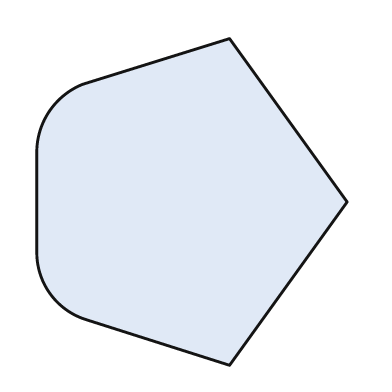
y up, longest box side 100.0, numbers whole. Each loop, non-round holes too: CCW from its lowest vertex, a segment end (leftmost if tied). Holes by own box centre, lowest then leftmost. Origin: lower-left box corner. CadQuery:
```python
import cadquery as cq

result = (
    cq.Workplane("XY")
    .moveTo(59.0, 0.0)
    .lineTo(95.0, 50.0)
    .lineTo(59.0, 100.0)
    .lineTo(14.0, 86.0)
    .threePointArc((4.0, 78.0), (0.0, 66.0))
    .lineTo(0.0, 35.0)
    .threePointArc((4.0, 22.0), (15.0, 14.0))
    .close()
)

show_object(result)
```